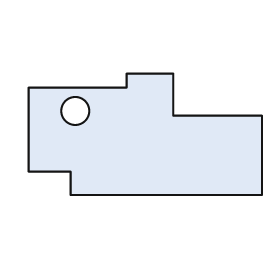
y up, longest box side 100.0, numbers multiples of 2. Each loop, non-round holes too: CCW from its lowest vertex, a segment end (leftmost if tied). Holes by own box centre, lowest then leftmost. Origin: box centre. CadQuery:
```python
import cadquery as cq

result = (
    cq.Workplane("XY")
    .moveTo(-32.0, -26.0)
    .lineTo(50.0, -26.0)
    .lineTo(50.0, 8.0)
    .lineTo(12.0, 8.0)
    .lineTo(12.0, 26.0)
    .lineTo(-8.0, 26.0)
    .lineTo(-8.0, 20.0)
    .lineTo(-50.0, 20.0)
    .lineTo(-50.0, -16.0)
    .lineTo(-32.0, -16.0)
    .close()
    .moveTo(-30.0, 10.0)
    .circle(6.0)
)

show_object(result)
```